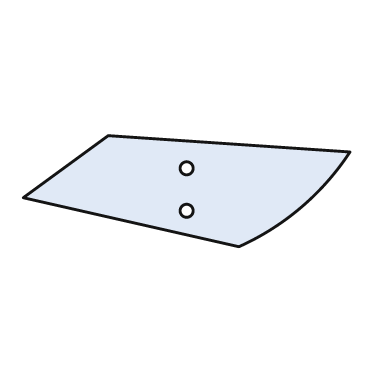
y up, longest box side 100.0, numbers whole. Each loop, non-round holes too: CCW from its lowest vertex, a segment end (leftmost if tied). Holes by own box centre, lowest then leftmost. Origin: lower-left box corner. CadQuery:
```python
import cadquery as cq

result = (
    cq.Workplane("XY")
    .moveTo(66.0, 0.0)
    .threePointArc((85.0, 12.0), (100.0, 29.0))
    .lineTo(26.0, 34.0)
    .lineTo(0.0, 15.0)
    .close()
    .moveTo(50.0, 11.0)
    .circle(2.0)
    .moveTo(50.0, 24.0)
    .circle(2.0)
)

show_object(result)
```